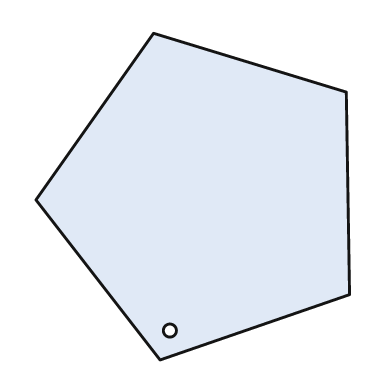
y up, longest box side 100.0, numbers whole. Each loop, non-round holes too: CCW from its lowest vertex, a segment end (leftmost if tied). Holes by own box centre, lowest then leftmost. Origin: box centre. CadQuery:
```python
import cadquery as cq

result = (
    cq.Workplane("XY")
    .moveTo(-10.0, -50.0)
    .lineTo(48.0, -30.0)
    .lineTo(47.0, 32.0)
    .lineTo(-12.0, 50.0)
    .lineTo(-48.0, -1.0)
    .close()
    .moveTo(-7.0, -41.0)
    .circle(2.0)
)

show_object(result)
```